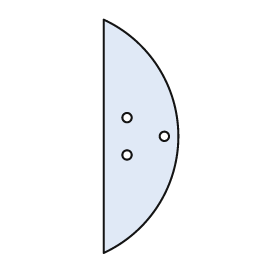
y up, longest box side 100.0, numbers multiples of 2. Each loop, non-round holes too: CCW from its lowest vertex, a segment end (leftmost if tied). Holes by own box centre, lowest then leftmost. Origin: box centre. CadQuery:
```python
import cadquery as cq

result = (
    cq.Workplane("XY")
    .moveTo(-16.0, -50.0)
    .threePointArc((16.0, 0.0), (-16.0, 50.0))
    .close()
    .moveTo(-6.0, -8.0)
    .circle(2.0)
    .moveTo(10.0, 0.0)
    .circle(2.0)
    .moveTo(-6.0, 8.0)
    .circle(2.0)
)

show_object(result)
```